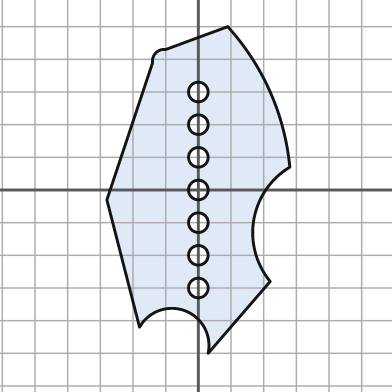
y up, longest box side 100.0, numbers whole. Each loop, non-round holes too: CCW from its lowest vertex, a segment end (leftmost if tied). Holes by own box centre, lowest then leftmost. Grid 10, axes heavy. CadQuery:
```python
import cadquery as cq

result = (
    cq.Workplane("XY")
    .moveTo(3.0, -50.0)
    .lineTo(22.0, -28.0)
    .threePointArc((17.0, -9.0), (28.0, 7.0))
    .threePointArc((22.0, 30.0), (9.0, 50.0))
    .lineTo(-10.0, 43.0)
    .threePointArc((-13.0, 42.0), (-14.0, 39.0))
    .lineTo(-28.0, -3.0)
    .lineTo(-18.0, -42.0)
    .threePointArc((-4.0, -37.0), (3.0, -50.0))
    .close()
    .moveTo(0.0, -30.0)
    .circle(3.0)
    .moveTo(0.0, -20.0)
    .circle(3.0)
    .moveTo(0.0, -10.0)
    .circle(3.0)
    .moveTo(0.0, 0.0)
    .circle(3.0)
    .moveTo(0.0, 10.0)
    .circle(3.0)
    .moveTo(0.0, 20.0)
    .circle(3.0)
    .moveTo(0.0, 30.0)
    .circle(3.0)
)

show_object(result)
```